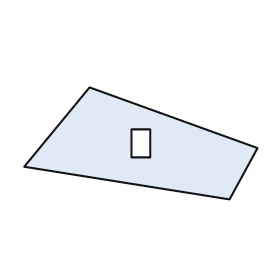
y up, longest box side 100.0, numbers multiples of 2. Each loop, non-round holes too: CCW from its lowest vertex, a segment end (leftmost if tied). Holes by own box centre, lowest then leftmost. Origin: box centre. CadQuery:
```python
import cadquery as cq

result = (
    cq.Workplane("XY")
    .moveTo(38.0, -24.0)
    .lineTo(50.0, -2.0)
    .lineTo(-22.0, 24.0)
    .lineTo(-50.0, -10.0)
    .close()
    .moveTo(-4.0, -6.0)
    .lineTo(4.0, -6.0)
    .lineTo(4.0, 6.0)
    .lineTo(-4.0, 6.0)
    .close()
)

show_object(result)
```